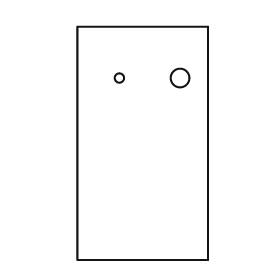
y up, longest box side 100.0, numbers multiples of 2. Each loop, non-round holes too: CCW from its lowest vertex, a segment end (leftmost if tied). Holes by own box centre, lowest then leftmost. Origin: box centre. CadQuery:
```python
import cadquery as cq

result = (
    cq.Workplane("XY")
    .moveTo(-28.0, -50.0)
    .lineTo(28.0, -50.0)
    .lineTo(28.0, 50.0)
    .lineTo(-28.0, 50.0)
    .close()
    .moveTo(-10.0, 28.0)
    .circle(2.0)
    .moveTo(16.0, 28.0)
    .circle(4.0)
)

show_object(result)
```